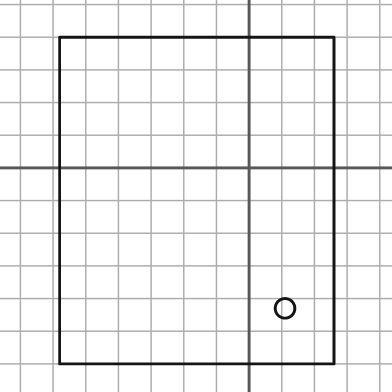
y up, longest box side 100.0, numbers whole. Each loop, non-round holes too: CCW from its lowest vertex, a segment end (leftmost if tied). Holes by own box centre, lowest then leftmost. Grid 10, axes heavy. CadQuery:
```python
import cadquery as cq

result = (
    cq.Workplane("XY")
    .moveTo(-58.0, -60.0)
    .lineTo(26.0, -60.0)
    .lineTo(26.0, 40.0)
    .lineTo(-58.0, 40.0)
    .close()
    .moveTo(11.0, -43.0)
    .circle(3.0)
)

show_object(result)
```